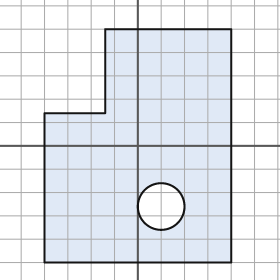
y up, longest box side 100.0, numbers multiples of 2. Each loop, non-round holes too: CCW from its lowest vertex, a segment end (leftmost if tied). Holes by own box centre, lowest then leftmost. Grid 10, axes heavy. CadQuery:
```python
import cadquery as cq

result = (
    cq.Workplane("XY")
    .moveTo(-40.0, -50.0)
    .lineTo(40.0, -50.0)
    .lineTo(40.0, 50.0)
    .lineTo(-14.0, 50.0)
    .lineTo(-14.0, 14.0)
    .lineTo(-40.0, 14.0)
    .close()
    .moveTo(10.0, -26.0)
    .circle(10.0)
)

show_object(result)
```